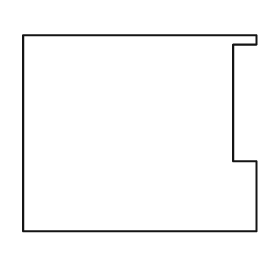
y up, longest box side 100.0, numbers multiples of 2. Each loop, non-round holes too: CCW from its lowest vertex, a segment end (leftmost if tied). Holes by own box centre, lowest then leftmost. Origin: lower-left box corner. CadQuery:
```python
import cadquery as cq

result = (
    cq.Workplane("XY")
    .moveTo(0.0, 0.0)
    .lineTo(100.0, 0.0)
    .lineTo(100.0, 30.0)
    .lineTo(90.0, 30.0)
    .lineTo(90.0, 80.0)
    .lineTo(100.0, 80.0)
    .lineTo(100.0, 84.0)
    .lineTo(0.0, 84.0)
    .close()
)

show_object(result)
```